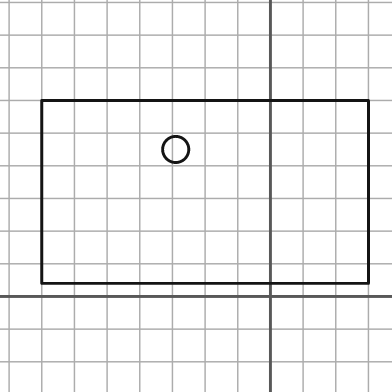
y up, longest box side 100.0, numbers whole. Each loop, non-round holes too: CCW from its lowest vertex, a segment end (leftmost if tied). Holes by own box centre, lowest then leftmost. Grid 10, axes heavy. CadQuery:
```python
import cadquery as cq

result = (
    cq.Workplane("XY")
    .moveTo(-70.0, 4.0)
    .lineTo(30.0, 4.0)
    .lineTo(30.0, 60.0)
    .lineTo(-70.0, 60.0)
    .close()
    .moveTo(-29.0, 45.0)
    .circle(4.0)
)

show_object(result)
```